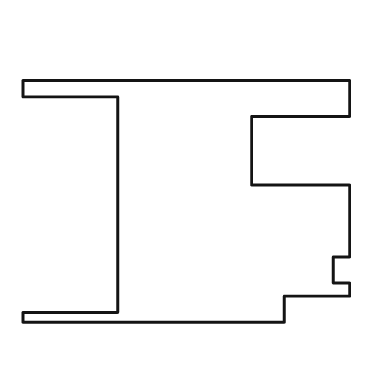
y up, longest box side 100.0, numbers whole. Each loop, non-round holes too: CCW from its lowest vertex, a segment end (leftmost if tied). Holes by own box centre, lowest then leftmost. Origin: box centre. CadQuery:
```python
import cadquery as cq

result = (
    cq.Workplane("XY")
    .moveTo(-50.0, -37.0)
    .lineTo(30.0, -37.0)
    .lineTo(30.0, -29.0)
    .lineTo(50.0, -29.0)
    .lineTo(50.0, -25.0)
    .lineTo(45.0, -25.0)
    .lineTo(45.0, -17.0)
    .lineTo(50.0, -17.0)
    .lineTo(50.0, 5.0)
    .lineTo(20.0, 5.0)
    .lineTo(20.0, 26.0)
    .lineTo(50.0, 26.0)
    .lineTo(50.0, 37.0)
    .lineTo(-50.0, 37.0)
    .lineTo(-50.0, 32.0)
    .lineTo(-21.0, 32.0)
    .lineTo(-21.0, -34.0)
    .lineTo(-50.0, -34.0)
    .close()
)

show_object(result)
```